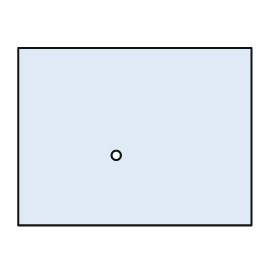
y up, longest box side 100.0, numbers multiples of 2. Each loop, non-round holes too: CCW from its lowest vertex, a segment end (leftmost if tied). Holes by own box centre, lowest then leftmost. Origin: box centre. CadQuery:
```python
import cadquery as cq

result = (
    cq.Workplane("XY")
    .moveTo(-50.0, -38.0)
    .lineTo(50.0, -38.0)
    .lineTo(50.0, 38.0)
    .lineTo(-50.0, 38.0)
    .close()
    .moveTo(-8.0, -8.0)
    .circle(2.0)
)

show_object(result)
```